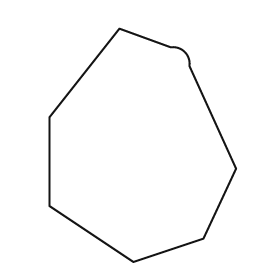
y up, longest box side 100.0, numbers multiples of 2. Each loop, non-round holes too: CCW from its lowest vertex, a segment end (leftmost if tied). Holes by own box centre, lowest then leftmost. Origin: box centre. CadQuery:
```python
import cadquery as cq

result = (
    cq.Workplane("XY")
    .moveTo(-4.0, -50.0)
    .lineTo(26.0, -40.0)
    .lineTo(40.0, -10.0)
    .lineTo(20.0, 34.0)
    .threePointArc((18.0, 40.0), (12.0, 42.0))
    .lineTo(-10.0, 50.0)
    .lineTo(-40.0, 12.0)
    .lineTo(-40.0, -26.0)
    .close()
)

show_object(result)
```